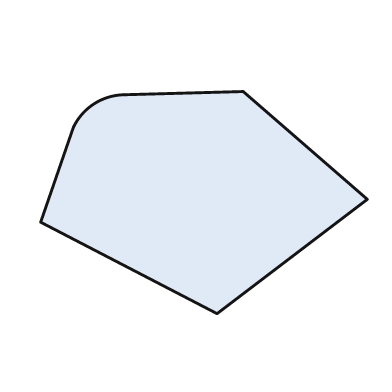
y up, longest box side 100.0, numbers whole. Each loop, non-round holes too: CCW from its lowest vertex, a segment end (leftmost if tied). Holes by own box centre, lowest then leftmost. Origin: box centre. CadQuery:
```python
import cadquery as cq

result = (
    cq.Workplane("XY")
    .moveTo(4.0, -34.0)
    .lineTo(50.0, 1.0)
    .lineTo(12.0, 34.0)
    .lineTo(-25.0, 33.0)
    .threePointArc((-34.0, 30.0), (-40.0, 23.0))
    .lineTo(-50.0, -6.0)
    .close()
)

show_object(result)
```